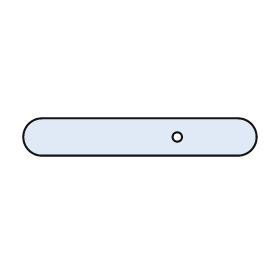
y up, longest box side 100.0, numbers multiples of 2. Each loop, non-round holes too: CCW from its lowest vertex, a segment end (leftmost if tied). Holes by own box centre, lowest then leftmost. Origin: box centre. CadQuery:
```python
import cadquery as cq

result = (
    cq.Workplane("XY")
    .moveTo(-42.0, -8.0)
    .lineTo(42.0, -8.0)
    .threePointArc((50.0, 0.0), (42.0, 8.0))
    .lineTo(-42.0, 8.0)
    .threePointArc((-50.0, 0.0), (-42.0, -8.0))
    .close()
    .moveTo(16.0, 0.0)
    .circle(2.0)
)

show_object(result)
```